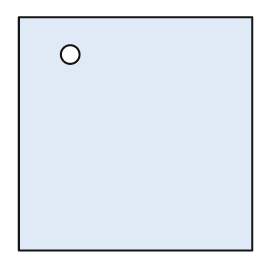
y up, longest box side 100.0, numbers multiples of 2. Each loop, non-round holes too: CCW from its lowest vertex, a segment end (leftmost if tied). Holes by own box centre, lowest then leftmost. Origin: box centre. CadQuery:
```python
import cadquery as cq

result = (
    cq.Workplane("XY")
    .moveTo(-50.0, -50.0)
    .lineTo(50.0, -50.0)
    .lineTo(50.0, 50.0)
    .lineTo(-50.0, 50.0)
    .close()
    .moveTo(-28.0, 34.0)
    .circle(4.0)
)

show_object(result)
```